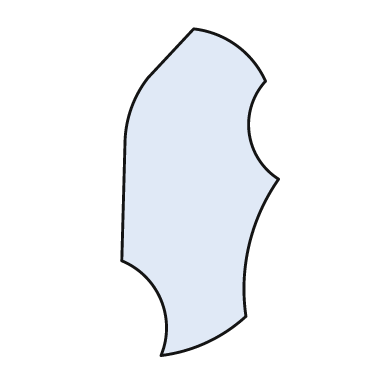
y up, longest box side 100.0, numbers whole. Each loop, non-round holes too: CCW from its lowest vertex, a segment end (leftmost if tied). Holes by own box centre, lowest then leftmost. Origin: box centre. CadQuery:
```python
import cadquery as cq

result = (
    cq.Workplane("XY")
    .moveTo(-12.0, -50.0)
    .threePointArc((2.0, -46.0), (14.0, -38.0))
    .threePointArc((15.0, -16.0), (24.0, 4.0))
    .threePointArc((15.0, 18.0), (20.0, 34.0))
    .threePointArc((11.0, 45.0), (-2.0, 50.0))
    .lineTo(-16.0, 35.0)
    .threePointArc((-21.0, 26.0), (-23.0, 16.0))
    .lineTo(-24.0, -21.0)
    .threePointArc((-12.0, -33.0), (-12.0, -50.0))
    .close()
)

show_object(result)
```